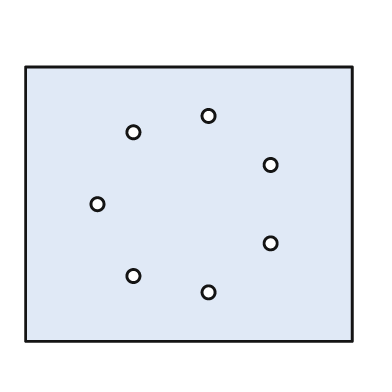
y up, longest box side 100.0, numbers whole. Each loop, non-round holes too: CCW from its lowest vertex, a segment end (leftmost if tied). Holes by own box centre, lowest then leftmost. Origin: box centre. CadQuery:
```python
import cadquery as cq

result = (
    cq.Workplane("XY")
    .moveTo(-50.0, -42.0)
    .lineTo(50.0, -42.0)
    .lineTo(50.0, 42.0)
    .lineTo(-50.0, 42.0)
    .close()
    .moveTo(6.0, -27.0)
    .circle(2.0)
    .moveTo(-17.0, -22.0)
    .circle(2.0)
    .moveTo(25.0, -12.0)
    .circle(2.0)
    .moveTo(-28.0, 0.0)
    .circle(2.0)
    .moveTo(25.0, 12.0)
    .circle(2.0)
    .moveTo(-17.0, 22.0)
    .circle(2.0)
    .moveTo(6.0, 27.0)
    .circle(2.0)
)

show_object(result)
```